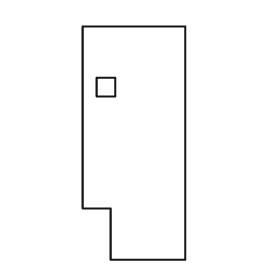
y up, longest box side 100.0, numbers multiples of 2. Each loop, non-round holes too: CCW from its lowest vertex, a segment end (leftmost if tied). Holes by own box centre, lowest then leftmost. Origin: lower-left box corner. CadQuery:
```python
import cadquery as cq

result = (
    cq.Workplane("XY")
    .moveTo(12.0, 0.0)
    .lineTo(44.0, 0.0)
    .lineTo(44.0, 100.0)
    .lineTo(0.0, 100.0)
    .lineTo(0.0, 22.0)
    .lineTo(12.0, 22.0)
    .close()
    .moveTo(6.0, 70.0)
    .lineTo(14.0, 70.0)
    .lineTo(14.0, 78.0)
    .lineTo(6.0, 78.0)
    .close()
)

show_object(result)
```